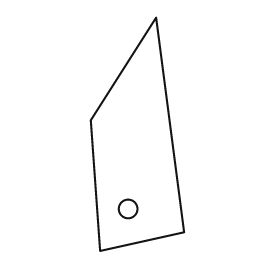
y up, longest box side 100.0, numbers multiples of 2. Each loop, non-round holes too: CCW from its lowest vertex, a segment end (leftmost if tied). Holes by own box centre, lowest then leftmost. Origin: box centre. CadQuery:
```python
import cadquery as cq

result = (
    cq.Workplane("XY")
    .moveTo(-16.0, -50.0)
    .lineTo(20.0, -42.0)
    .lineTo(8.0, 50.0)
    .lineTo(-20.0, 6.0)
    .close()
    .moveTo(-4.0, -32.0)
    .circle(4.0)
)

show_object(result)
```